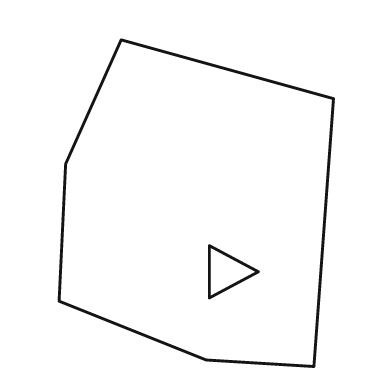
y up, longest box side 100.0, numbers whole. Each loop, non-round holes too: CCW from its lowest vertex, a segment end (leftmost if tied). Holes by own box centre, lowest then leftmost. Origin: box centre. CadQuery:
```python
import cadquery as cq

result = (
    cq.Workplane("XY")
    .moveTo(36.0, -50.0)
    .lineTo(42.0, 32.0)
    .lineTo(-23.0, 50.0)
    .lineTo(-40.0, 12.0)
    .lineTo(-42.0, -30.0)
    .lineTo(3.0, -48.0)
    .close()
    .moveTo(4.0, -29.0)
    .lineTo(19.0, -21.0)
    .lineTo(4.0, -13.0)
    .close()
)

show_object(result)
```